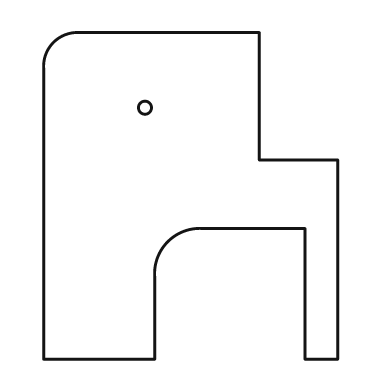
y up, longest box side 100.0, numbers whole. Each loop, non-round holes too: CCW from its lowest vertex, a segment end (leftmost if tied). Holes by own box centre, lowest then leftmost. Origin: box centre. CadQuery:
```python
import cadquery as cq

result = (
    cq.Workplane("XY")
    .moveTo(-45.0, -50.0)
    .lineTo(-11.0, -50.0)
    .lineTo(-11.0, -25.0)
    .threePointArc((-7.0, -14.0), (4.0, -10.0))
    .lineTo(35.0, -10.0)
    .lineTo(35.0, -50.0)
    .lineTo(45.0, -50.0)
    .lineTo(45.0, 11.0)
    .lineTo(21.0, 11.0)
    .lineTo(21.0, 50.0)
    .lineTo(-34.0, 50.0)
    .threePointArc((-42.0, 47.0), (-45.0, 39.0))
    .close()
    .moveTo(-14.0, 27.0)
    .circle(2.0)
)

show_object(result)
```